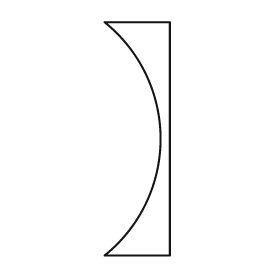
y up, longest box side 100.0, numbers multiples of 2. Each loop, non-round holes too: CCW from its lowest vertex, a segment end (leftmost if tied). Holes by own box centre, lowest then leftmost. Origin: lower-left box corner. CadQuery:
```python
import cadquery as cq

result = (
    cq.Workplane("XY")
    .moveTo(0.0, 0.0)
    .lineTo(28.0, 0.0)
    .lineTo(28.0, 100.0)
    .lineTo(0.0, 100.0)
    .threePointArc((24.0, 50.0), (0.0, 0.0))
    .close()
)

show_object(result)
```